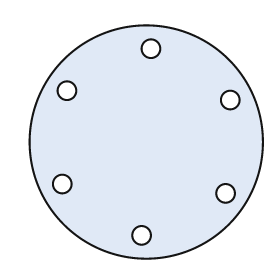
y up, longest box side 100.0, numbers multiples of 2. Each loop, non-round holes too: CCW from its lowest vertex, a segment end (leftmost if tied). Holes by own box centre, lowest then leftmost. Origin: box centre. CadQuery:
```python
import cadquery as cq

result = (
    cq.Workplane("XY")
    .moveTo(0.0, 0.0)
    .circle(50.0)
    .moveTo(-2.0, -40.0)
    .circle(4.0)
    .moveTo(34.0, -22.0)
    .circle(4.0)
    .moveTo(-36.0, -18.0)
    .circle(4.0)
    .moveTo(36.0, 18.0)
    .circle(4.0)
    .moveTo(-34.0, 22.0)
    .circle(4.0)
    .moveTo(2.0, 40.0)
    .circle(4.0)
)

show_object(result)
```